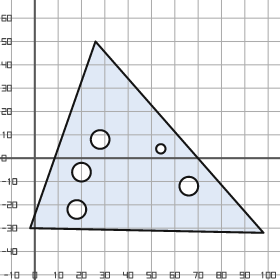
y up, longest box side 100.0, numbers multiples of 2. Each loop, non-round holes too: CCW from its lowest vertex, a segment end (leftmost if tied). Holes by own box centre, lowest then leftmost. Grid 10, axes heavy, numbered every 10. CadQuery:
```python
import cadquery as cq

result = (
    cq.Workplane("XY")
    .moveTo(98.0, -32.0)
    .lineTo(26.0, 50.0)
    .lineTo(-2.0, -30.0)
    .close()
    .moveTo(18.0, -22.0)
    .circle(4.0)
    .moveTo(66.0, -12.0)
    .circle(4.0)
    .moveTo(20.0, -6.0)
    .circle(4.0)
    .moveTo(54.0, 4.0)
    .circle(2.0)
    .moveTo(28.0, 8.0)
    .circle(4.0)
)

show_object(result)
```